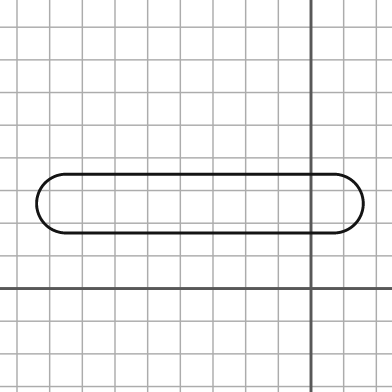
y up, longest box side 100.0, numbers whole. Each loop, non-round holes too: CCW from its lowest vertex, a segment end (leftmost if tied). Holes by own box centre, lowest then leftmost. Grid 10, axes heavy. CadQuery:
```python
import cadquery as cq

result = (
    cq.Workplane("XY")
    .moveTo(-75.0, 17.0)
    .lineTo(7.0, 17.0)
    .threePointArc((16.0, 26.0), (7.0, 35.0))
    .lineTo(-75.0, 35.0)
    .threePointArc((-84.0, 26.0), (-75.0, 17.0))
    .close()
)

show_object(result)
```